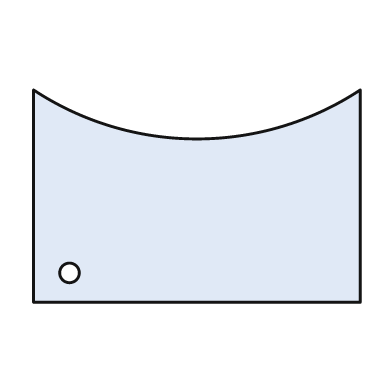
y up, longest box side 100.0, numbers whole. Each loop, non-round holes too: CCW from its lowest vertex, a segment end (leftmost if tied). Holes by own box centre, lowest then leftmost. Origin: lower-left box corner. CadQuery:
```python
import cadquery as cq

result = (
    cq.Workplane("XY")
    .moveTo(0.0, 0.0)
    .lineTo(100.0, 0.0)
    .lineTo(100.0, 65.0)
    .threePointArc((50.0, 50.0), (0.0, 65.0))
    .close()
    .moveTo(11.0, 9.0)
    .circle(3.0)
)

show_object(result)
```